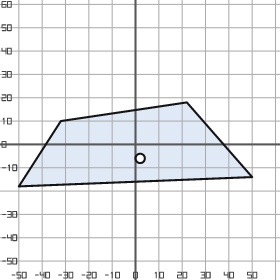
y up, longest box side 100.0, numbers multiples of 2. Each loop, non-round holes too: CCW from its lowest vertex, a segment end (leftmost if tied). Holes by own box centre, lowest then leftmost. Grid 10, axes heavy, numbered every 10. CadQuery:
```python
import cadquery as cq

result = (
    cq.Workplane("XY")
    .moveTo(-50.0, -18.0)
    .lineTo(50.0, -14.0)
    .lineTo(22.0, 18.0)
    .lineTo(-32.0, 10.0)
    .close()
    .moveTo(2.0, -6.0)
    .circle(2.0)
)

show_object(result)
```